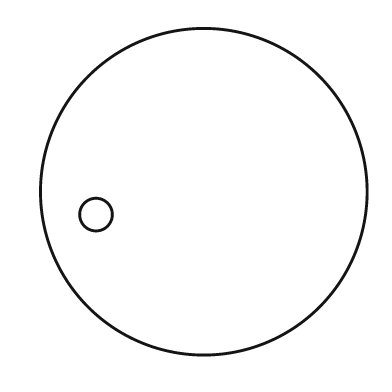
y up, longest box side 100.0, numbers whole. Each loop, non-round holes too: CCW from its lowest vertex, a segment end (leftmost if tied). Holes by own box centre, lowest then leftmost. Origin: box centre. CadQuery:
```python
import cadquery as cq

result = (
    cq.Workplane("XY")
    .moveTo(0.0, 0.0)
    .circle(50.0)
    .moveTo(-33.0, -7.0)
    .circle(5.0)
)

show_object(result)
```